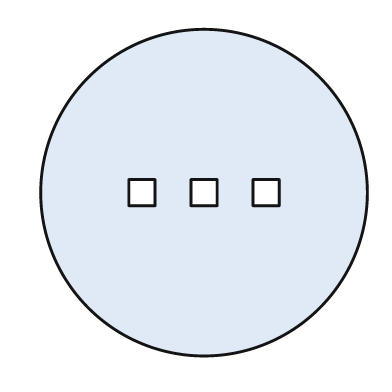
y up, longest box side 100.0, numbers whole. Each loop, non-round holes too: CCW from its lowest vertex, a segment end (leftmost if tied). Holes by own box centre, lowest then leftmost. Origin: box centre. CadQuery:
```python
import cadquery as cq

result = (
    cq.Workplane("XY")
    .moveTo(0.0, 0.0)
    .circle(50.0)
    .moveTo(-23.0, -4.0)
    .lineTo(-15.0, -4.0)
    .lineTo(-15.0, 4.0)
    .lineTo(-23.0, 4.0)
    .close()
    .moveTo(-4.0, -4.0)
    .lineTo(4.0, -4.0)
    .lineTo(4.0, 4.0)
    .lineTo(-4.0, 4.0)
    .close()
    .moveTo(15.0, -4.0)
    .lineTo(23.0, -4.0)
    .lineTo(23.0, 4.0)
    .lineTo(15.0, 4.0)
    .close()
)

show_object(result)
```